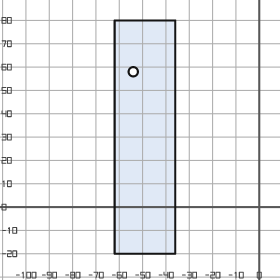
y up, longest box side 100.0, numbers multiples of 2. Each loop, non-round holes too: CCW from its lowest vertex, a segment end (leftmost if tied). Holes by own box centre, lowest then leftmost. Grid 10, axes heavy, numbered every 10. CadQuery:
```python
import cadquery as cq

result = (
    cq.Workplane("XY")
    .moveTo(-62.0, -20.0)
    .lineTo(-36.0, -20.0)
    .lineTo(-36.0, 80.0)
    .lineTo(-62.0, 80.0)
    .close()
    .moveTo(-54.0, 58.0)
    .circle(2.0)
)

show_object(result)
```